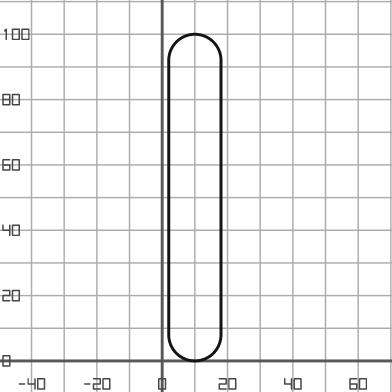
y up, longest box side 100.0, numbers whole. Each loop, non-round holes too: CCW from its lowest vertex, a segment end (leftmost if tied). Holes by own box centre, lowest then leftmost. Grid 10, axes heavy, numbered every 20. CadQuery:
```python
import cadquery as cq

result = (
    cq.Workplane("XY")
    .moveTo(2.0, 8.0)
    .threePointArc((10.0, 0.0), (18.0, 8.0))
    .lineTo(18.0, 92.0)
    .threePointArc((10.0, 100.0), (2.0, 92.0))
    .close()
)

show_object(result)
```